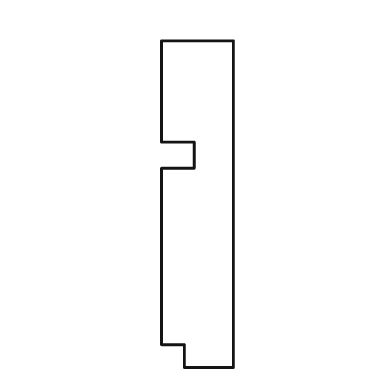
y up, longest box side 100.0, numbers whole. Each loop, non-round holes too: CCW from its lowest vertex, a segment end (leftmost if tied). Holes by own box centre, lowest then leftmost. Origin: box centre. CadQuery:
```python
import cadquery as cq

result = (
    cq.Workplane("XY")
    .moveTo(-4.0, -50.0)
    .lineTo(11.0, -50.0)
    .lineTo(11.0, 50.0)
    .lineTo(-11.0, 50.0)
    .lineTo(-11.0, 19.0)
    .lineTo(-1.0, 19.0)
    .lineTo(-1.0, 11.0)
    .lineTo(-11.0, 11.0)
    .lineTo(-11.0, -43.0)
    .lineTo(-4.0, -43.0)
    .close()
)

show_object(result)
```